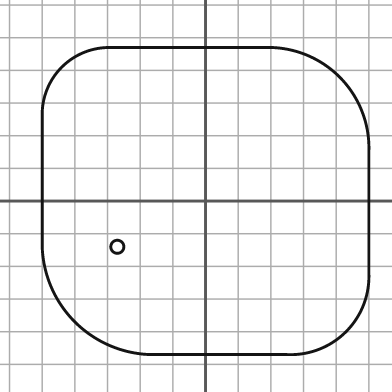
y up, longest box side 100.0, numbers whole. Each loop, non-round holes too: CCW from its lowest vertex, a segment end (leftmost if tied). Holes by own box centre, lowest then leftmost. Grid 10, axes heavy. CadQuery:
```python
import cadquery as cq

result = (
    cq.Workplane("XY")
    .moveTo(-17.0, -47.0)
    .lineTo(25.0, -47.0)
    .threePointArc((43.0, -40.0), (50.0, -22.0))
    .lineTo(50.0, 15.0)
    .threePointArc((41.0, 38.0), (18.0, 47.0))
    .lineTo(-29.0, 47.0)
    .threePointArc((-44.0, 41.0), (-50.0, 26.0))
    .lineTo(-50.0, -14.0)
    .threePointArc((-40.0, -37.0), (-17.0, -47.0))
    .close()
    .moveTo(-27.0, -14.0)
    .circle(2.0)
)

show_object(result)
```